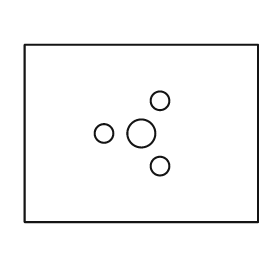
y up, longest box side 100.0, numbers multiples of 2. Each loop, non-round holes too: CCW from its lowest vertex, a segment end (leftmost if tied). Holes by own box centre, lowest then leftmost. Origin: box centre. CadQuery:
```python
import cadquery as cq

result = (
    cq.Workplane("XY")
    .moveTo(-50.0, -38.0)
    .lineTo(50.0, -38.0)
    .lineTo(50.0, 38.0)
    .lineTo(-50.0, 38.0)
    .close()
    .moveTo(8.0, -14.0)
    .circle(4.0)
    .moveTo(-16.0, 0.0)
    .circle(4.0)
    .moveTo(0.0, 0.0)
    .circle(6.0)
    .moveTo(8.0, 14.0)
    .circle(4.0)
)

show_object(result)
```